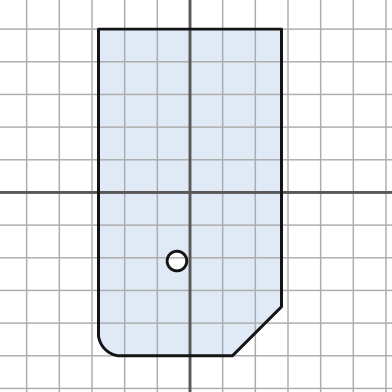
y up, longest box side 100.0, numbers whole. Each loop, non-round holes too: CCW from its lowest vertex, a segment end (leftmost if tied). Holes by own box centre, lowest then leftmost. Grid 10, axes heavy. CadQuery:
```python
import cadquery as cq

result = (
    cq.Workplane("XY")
    .moveTo(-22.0, -50.0)
    .lineTo(13.0, -50.0)
    .lineTo(28.0, -35.0)
    .lineTo(28.0, 50.0)
    .lineTo(-28.0, 50.0)
    .lineTo(-28.0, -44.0)
    .threePointArc((-26.0, -48.0), (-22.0, -50.0))
    .close()
    .moveTo(-4.0, -21.0)
    .circle(3.0)
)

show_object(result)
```